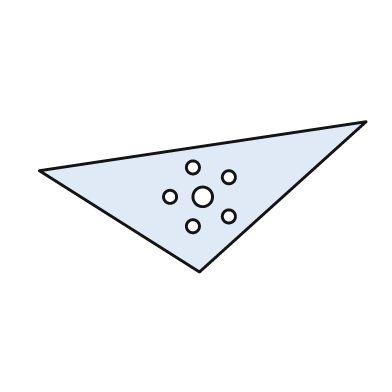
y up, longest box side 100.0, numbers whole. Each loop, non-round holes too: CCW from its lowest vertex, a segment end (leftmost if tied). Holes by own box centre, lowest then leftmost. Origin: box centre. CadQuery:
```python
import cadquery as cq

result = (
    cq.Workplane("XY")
    .moveTo(-1.0, -23.0)
    .lineTo(50.0, 23.0)
    .lineTo(-50.0, 8.0)
    .close()
    .moveTo(-3.0, -9.0)
    .circle(2.0)
    .moveTo(8.0, -6.0)
    .circle(2.0)
    .moveTo(-10.0, 0.0)
    .circle(2.0)
    .moveTo(0.0, 0.0)
    .circle(3.0)
    .moveTo(8.0, 6.0)
    .circle(2.0)
    .moveTo(-3.0, 9.0)
    .circle(2.0)
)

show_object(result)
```